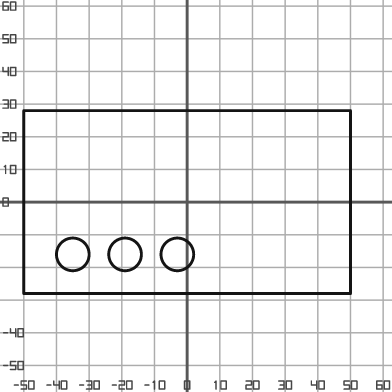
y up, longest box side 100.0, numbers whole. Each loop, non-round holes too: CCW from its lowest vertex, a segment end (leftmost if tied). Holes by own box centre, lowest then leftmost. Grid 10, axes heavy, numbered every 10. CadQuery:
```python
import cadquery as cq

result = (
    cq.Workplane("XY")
    .moveTo(-50.0, -28.0)
    .lineTo(50.0, -28.0)
    .lineTo(50.0, 28.0)
    .lineTo(-50.0, 28.0)
    .close()
    .moveTo(-35.0, -16.0)
    .circle(5.0)
    .moveTo(-19.0, -16.0)
    .circle(5.0)
    .moveTo(-3.0, -16.0)
    .circle(5.0)
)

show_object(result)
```